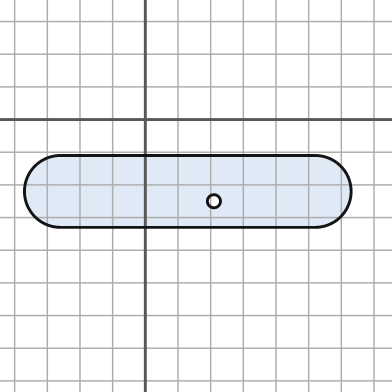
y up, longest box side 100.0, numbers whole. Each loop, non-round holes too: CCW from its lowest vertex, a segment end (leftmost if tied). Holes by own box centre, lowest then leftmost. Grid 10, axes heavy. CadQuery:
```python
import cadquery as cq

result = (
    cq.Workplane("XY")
    .moveTo(-26.0, -33.0)
    .lineTo(52.0, -33.0)
    .threePointArc((63.0, -22.0), (52.0, -11.0))
    .lineTo(-26.0, -11.0)
    .threePointArc((-37.0, -22.0), (-26.0, -33.0))
    .close()
    .moveTo(21.0, -25.0)
    .circle(2.0)
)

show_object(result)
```